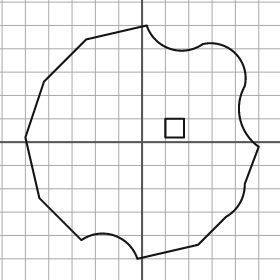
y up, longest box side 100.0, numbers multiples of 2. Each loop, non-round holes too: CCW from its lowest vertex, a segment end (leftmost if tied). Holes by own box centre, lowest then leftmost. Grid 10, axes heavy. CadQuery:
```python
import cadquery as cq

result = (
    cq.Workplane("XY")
    .moveTo(-2.0, -50.0)
    .lineTo(24.0, -44.0)
    .lineTo(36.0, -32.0)
    .threePointArc((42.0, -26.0), (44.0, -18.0))
    .lineTo(50.0, -2.0)
    .threePointArc((42.0, 10.0), (44.0, 24.0))
    .threePointArc((40.0, 38.0), (26.0, 42.0))
    .threePointArc((12.0, 40.0), (2.0, 50.0))
    .lineTo(-24.0, 44.0)
    .lineTo(-42.0, 26.0)
    .lineTo(-50.0, 2.0)
    .lineTo(-44.0, -24.0)
    .lineTo(-26.0, -42.0)
    .threePointArc((-12.0, -40.0), (-2.0, -50.0))
    .close()
    .moveTo(10.0, 2.0)
    .lineTo(18.0, 2.0)
    .lineTo(18.0, 10.0)
    .lineTo(10.0, 10.0)
    .close()
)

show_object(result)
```